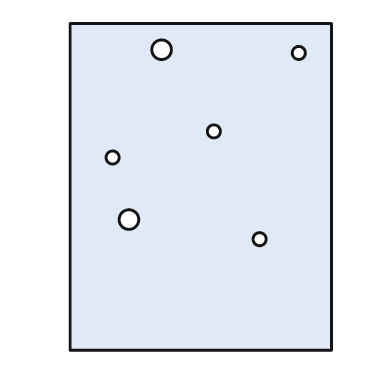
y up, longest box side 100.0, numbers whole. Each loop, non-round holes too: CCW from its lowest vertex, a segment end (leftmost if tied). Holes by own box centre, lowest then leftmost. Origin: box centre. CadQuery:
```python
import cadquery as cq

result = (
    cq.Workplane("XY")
    .moveTo(-40.0, -50.0)
    .lineTo(40.0, -50.0)
    .lineTo(40.0, 50.0)
    .lineTo(-40.0, 50.0)
    .close()
    .moveTo(18.0, -16.0)
    .circle(2.0)
    .moveTo(-22.0, -10.0)
    .circle(3.0)
    .moveTo(-27.0, 9.0)
    .circle(2.0)
    .moveTo(4.0, 17.0)
    .circle(2.0)
    .moveTo(30.0, 41.0)
    .circle(2.0)
    .moveTo(-12.0, 42.0)
    .circle(3.0)
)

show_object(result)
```